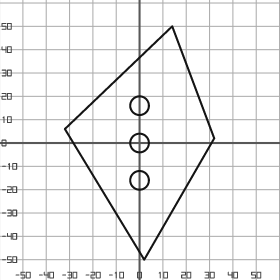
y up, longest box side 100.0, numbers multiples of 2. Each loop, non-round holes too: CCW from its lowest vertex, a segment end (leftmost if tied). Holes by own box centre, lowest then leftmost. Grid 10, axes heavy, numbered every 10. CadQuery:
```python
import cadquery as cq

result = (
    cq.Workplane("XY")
    .moveTo(2.0, -50.0)
    .lineTo(32.0, 2.0)
    .lineTo(14.0, 50.0)
    .lineTo(-32.0, 6.0)
    .close()
    .moveTo(0.0, -16.0)
    .circle(4.0)
    .moveTo(0.0, 0.0)
    .circle(4.0)
    .moveTo(0.0, 16.0)
    .circle(4.0)
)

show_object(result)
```